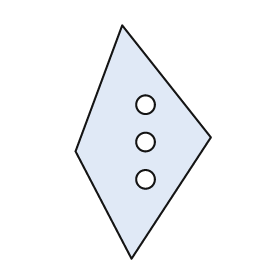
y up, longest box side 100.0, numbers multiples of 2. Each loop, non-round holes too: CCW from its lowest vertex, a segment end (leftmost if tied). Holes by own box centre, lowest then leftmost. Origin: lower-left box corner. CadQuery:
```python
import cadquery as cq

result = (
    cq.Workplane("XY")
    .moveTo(24.0, 0.0)
    .lineTo(58.0, 52.0)
    .lineTo(20.0, 100.0)
    .lineTo(0.0, 46.0)
    .close()
    .moveTo(30.0, 34.0)
    .circle(4.0)
    .moveTo(30.0, 50.0)
    .circle(4.0)
    .moveTo(30.0, 66.0)
    .circle(4.0)
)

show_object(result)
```